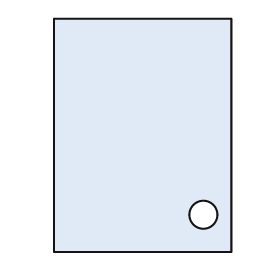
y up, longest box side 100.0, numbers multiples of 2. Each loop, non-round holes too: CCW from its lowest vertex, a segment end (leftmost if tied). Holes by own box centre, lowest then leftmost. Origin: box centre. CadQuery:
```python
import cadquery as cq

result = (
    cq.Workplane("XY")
    .moveTo(-38.0, -50.0)
    .lineTo(38.0, -50.0)
    .lineTo(38.0, 50.0)
    .lineTo(-38.0, 50.0)
    .close()
    .moveTo(26.0, -34.0)
    .circle(6.0)
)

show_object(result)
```